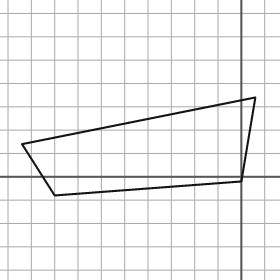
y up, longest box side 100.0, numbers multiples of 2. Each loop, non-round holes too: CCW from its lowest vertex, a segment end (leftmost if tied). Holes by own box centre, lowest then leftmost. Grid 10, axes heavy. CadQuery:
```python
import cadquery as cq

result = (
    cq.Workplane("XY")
    .moveTo(-80.0, -8.0)
    .lineTo(0.0, -2.0)
    .lineTo(6.0, 34.0)
    .lineTo(-94.0, 14.0)
    .close()
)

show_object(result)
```